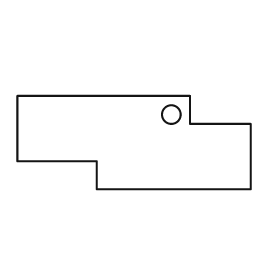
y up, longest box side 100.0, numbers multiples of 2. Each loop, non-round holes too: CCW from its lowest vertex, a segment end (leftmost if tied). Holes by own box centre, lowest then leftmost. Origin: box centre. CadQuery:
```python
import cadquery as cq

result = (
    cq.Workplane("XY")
    .moveTo(-16.0, -20.0)
    .lineTo(50.0, -20.0)
    .lineTo(50.0, 8.0)
    .lineTo(24.0, 8.0)
    .lineTo(24.0, 20.0)
    .lineTo(-50.0, 20.0)
    .lineTo(-50.0, -8.0)
    .lineTo(-16.0, -8.0)
    .close()
    .moveTo(16.0, 12.0)
    .circle(4.0)
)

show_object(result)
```